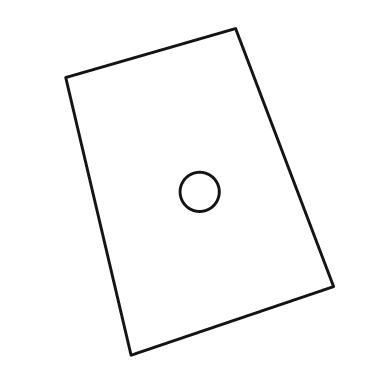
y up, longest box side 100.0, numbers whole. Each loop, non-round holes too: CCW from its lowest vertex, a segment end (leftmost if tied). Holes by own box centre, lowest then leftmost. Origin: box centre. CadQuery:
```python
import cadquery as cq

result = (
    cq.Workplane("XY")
    .moveTo(-21.0, -50.0)
    .lineTo(41.0, -29.0)
    .lineTo(11.0, 50.0)
    .lineTo(-41.0, 35.0)
    .close()
    .moveTo(0.0, 0.0)
    .circle(6.0)
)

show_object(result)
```